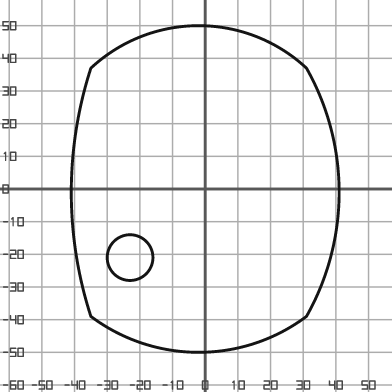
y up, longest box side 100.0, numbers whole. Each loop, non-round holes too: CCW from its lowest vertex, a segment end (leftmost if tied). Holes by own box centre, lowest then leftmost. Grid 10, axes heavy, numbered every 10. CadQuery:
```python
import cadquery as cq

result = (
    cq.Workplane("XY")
    .moveTo(-35.0, -39.0)
    .threePointArc((-2.0, -50.0), (31.0, -39.0))
    .threePointArc((41.0, -1.0), (31.0, 37.0))
    .threePointArc((-2.0, 50.0), (-35.0, 37.0))
    .threePointArc((-41.0, -1.0), (-35.0, -39.0))
    .close()
    .moveTo(-23.0, -21.0)
    .circle(7.0)
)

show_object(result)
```